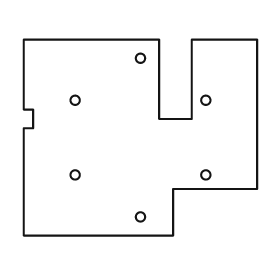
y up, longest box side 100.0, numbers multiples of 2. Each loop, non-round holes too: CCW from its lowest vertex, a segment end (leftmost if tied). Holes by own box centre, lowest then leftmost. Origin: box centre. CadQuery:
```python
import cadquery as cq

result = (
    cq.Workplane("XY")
    .moveTo(-50.0, -42.0)
    .lineTo(14.0, -42.0)
    .lineTo(14.0, -22.0)
    .lineTo(50.0, -22.0)
    .lineTo(50.0, 42.0)
    .lineTo(22.0, 42.0)
    .lineTo(22.0, 8.0)
    .lineTo(8.0, 8.0)
    .lineTo(8.0, 42.0)
    .lineTo(-50.0, 42.0)
    .lineTo(-50.0, 12.0)
    .lineTo(-46.0, 12.0)
    .lineTo(-46.0, 4.0)
    .lineTo(-50.0, 4.0)
    .close()
    .moveTo(0.0, -34.0)
    .circle(2.0)
    .moveTo(-28.0, -16.0)
    .circle(2.0)
    .moveTo(28.0, -16.0)
    .circle(2.0)
    .moveTo(-28.0, 16.0)
    .circle(2.0)
    .moveTo(28.0, 16.0)
    .circle(2.0)
    .moveTo(0.0, 34.0)
    .circle(2.0)
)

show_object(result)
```